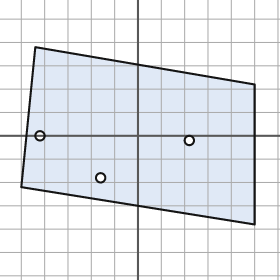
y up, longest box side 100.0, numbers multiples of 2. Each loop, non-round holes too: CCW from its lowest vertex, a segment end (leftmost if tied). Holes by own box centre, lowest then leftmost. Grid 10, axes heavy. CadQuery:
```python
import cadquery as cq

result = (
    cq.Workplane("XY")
    .moveTo(50.0, -38.0)
    .lineTo(50.0, 22.0)
    .lineTo(-44.0, 38.0)
    .lineTo(-50.0, -22.0)
    .close()
    .moveTo(-16.0, -18.0)
    .circle(2.0)
    .moveTo(22.0, -2.0)
    .circle(2.0)
    .moveTo(-42.0, 0.0)
    .circle(2.0)
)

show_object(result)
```